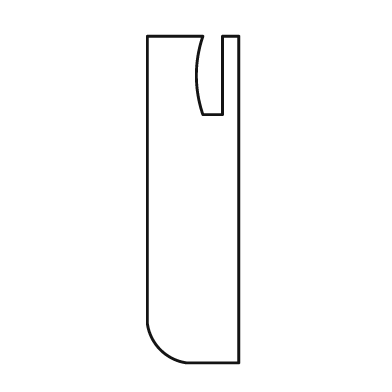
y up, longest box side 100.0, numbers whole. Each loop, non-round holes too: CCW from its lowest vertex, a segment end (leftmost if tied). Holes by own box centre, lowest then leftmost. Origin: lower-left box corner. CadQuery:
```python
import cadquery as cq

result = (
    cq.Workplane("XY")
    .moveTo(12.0, 0.0)
    .lineTo(28.0, 0.0)
    .lineTo(28.0, 100.0)
    .lineTo(23.0, 100.0)
    .lineTo(23.0, 76.0)
    .lineTo(17.0, 76.0)
    .threePointArc((15.0, 88.0), (17.0, 100.0))
    .lineTo(0.0, 100.0)
    .lineTo(0.0, 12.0)
    .threePointArc((4.0, 4.0), (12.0, 0.0))
    .close()
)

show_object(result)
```